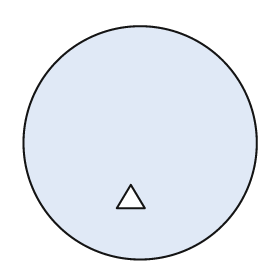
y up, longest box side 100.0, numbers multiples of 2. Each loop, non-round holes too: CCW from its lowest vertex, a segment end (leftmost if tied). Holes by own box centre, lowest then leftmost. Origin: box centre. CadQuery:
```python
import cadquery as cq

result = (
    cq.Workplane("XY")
    .moveTo(0.0, 0.0)
    .circle(50.0)
    .moveTo(-10.0, -28.0)
    .lineTo(2.0, -28.0)
    .lineTo(-4.0, -18.0)
    .close()
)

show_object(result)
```